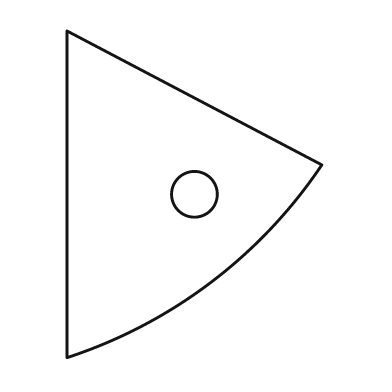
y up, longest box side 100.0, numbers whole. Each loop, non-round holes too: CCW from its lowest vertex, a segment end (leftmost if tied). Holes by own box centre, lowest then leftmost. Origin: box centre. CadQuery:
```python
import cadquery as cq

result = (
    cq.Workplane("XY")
    .moveTo(-39.0, -50.0)
    .threePointArc((5.0, -27.0), (39.0, 9.0))
    .lineTo(-39.0, 50.0)
    .close()
    .moveTo(0.0, 0.0)
    .circle(7.0)
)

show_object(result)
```